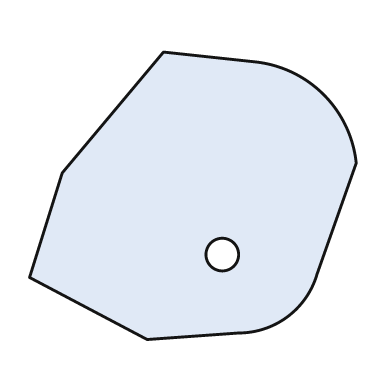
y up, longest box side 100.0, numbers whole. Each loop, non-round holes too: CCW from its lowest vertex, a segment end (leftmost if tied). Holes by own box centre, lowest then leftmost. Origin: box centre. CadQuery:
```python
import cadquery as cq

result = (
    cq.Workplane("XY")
    .moveTo(-14.0, -44.0)
    .lineTo(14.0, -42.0)
    .threePointArc((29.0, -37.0), (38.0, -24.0))
    .lineTo(50.0, 10.0)
    .threePointArc((40.0, 31.0), (19.0, 41.0))
    .lineTo(-9.0, 44.0)
    .lineTo(-40.0, 7.0)
    .lineTo(-50.0, -25.0)
    .close()
    .moveTo(9.0, -18.0)
    .circle(5.0)
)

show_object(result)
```